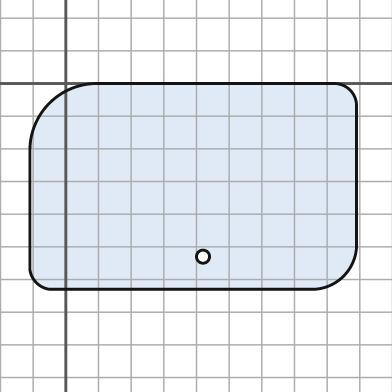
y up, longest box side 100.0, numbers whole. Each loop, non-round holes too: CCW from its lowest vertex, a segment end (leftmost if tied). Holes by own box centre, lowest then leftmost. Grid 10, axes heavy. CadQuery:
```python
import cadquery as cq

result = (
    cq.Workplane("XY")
    .moveTo(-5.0, -63.0)
    .lineTo(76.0, -63.0)
    .threePointArc((85.0, -59.0), (89.0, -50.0))
    .lineTo(89.0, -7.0)
    .threePointArc((87.0, -2.0), (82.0, 0.0))
    .lineTo(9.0, 0.0)
    .threePointArc((-5.0, -6.0), (-11.0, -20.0))
    .lineTo(-11.0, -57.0)
    .threePointArc((-9.0, -61.0), (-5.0, -63.0))
    .close()
    .moveTo(42.0, -53.0)
    .circle(2.0)
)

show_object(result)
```